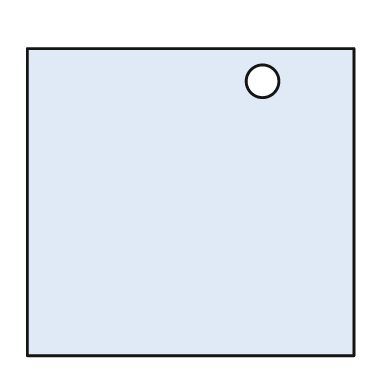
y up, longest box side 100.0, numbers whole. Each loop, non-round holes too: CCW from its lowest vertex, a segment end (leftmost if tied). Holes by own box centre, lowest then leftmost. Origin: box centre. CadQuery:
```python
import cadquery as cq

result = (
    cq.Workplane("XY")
    .moveTo(-50.0, -47.0)
    .lineTo(50.0, -47.0)
    .lineTo(50.0, 47.0)
    .lineTo(-50.0, 47.0)
    .close()
    .moveTo(22.0, 37.0)
    .circle(5.0)
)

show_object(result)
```